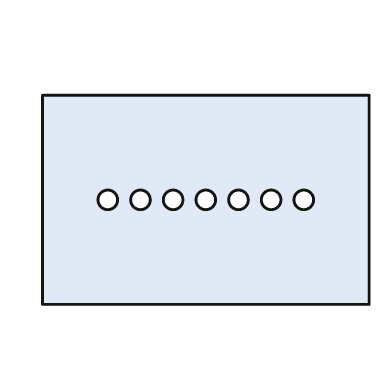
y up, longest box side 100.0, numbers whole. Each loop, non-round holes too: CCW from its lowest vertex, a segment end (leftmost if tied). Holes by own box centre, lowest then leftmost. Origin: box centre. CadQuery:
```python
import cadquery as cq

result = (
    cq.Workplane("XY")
    .moveTo(-50.0, -32.0)
    .lineTo(50.0, -32.0)
    .lineTo(50.0, 32.0)
    .lineTo(-50.0, 32.0)
    .close()
    .moveTo(-30.0, 0.0)
    .circle(3.0)
    .moveTo(-20.0, 0.0)
    .circle(3.0)
    .moveTo(-10.0, 0.0)
    .circle(3.0)
    .moveTo(0.0, 0.0)
    .circle(3.0)
    .moveTo(10.0, 0.0)
    .circle(3.0)
    .moveTo(20.0, 0.0)
    .circle(3.0)
    .moveTo(30.0, 0.0)
    .circle(3.0)
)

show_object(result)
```